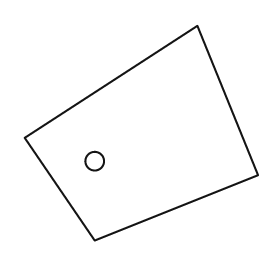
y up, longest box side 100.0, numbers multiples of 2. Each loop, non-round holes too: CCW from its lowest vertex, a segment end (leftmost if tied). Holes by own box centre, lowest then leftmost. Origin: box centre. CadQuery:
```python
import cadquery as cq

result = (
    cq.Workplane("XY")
    .moveTo(-20.0, -46.0)
    .lineTo(50.0, -18.0)
    .lineTo(24.0, 46.0)
    .lineTo(-50.0, -2.0)
    .close()
    .moveTo(-20.0, -12.0)
    .circle(4.0)
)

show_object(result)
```